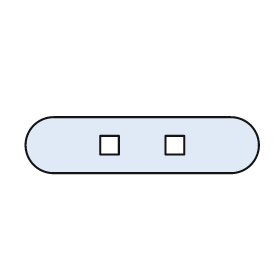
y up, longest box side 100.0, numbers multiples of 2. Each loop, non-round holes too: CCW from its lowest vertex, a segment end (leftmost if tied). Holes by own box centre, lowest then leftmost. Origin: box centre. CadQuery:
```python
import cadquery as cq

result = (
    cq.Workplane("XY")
    .moveTo(-38.0, -12.0)
    .lineTo(38.0, -12.0)
    .threePointArc((50.0, 0.0), (38.0, 12.0))
    .lineTo(-38.0, 12.0)
    .threePointArc((-50.0, 0.0), (-38.0, -12.0))
    .close()
    .moveTo(-18.0, -4.0)
    .lineTo(-10.0, -4.0)
    .lineTo(-10.0, 4.0)
    .lineTo(-18.0, 4.0)
    .close()
    .moveTo(10.0, -4.0)
    .lineTo(18.0, -4.0)
    .lineTo(18.0, 4.0)
    .lineTo(10.0, 4.0)
    .close()
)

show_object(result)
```